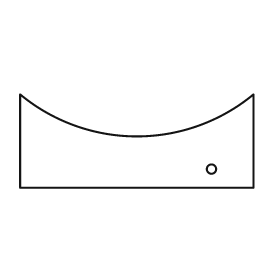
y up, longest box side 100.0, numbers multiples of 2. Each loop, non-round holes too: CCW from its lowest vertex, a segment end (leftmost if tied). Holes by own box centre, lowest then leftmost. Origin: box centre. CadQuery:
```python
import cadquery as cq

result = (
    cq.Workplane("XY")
    .moveTo(-50.0, -20.0)
    .lineTo(50.0, -20.0)
    .lineTo(50.0, 20.0)
    .threePointArc((0.0, 2.0), (-50.0, 20.0))
    .close()
    .moveTo(32.0, -12.0)
    .circle(2.0)
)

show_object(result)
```